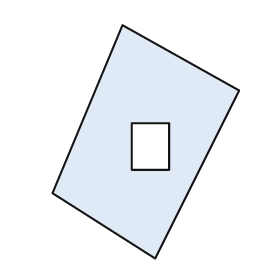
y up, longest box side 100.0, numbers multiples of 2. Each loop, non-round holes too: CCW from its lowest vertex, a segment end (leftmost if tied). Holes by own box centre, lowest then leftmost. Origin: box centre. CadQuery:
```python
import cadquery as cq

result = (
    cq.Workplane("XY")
    .moveTo(4.0, -50.0)
    .lineTo(40.0, 22.0)
    .lineTo(-10.0, 50.0)
    .lineTo(-40.0, -22.0)
    .close()
    .moveTo(-6.0, -12.0)
    .lineTo(10.0, -12.0)
    .lineTo(10.0, 8.0)
    .lineTo(-6.0, 8.0)
    .close()
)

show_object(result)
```